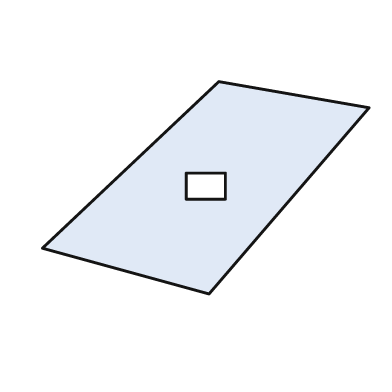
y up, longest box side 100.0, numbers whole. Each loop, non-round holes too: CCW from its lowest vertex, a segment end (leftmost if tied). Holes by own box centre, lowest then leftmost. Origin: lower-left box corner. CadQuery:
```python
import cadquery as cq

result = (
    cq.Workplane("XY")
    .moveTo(51.0, 0.0)
    .lineTo(100.0, 57.0)
    .lineTo(54.0, 65.0)
    .lineTo(0.0, 14.0)
    .close()
    .moveTo(44.0, 29.0)
    .lineTo(56.0, 29.0)
    .lineTo(56.0, 37.0)
    .lineTo(44.0, 37.0)
    .close()
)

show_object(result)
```